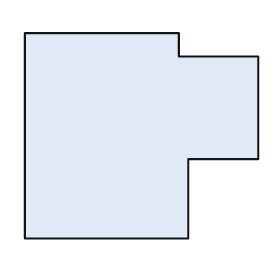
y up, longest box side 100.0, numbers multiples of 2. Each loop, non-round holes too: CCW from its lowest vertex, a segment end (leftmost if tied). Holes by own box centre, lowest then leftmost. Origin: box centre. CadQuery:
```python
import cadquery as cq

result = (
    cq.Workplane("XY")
    .moveTo(-50.0, -44.0)
    .lineTo(20.0, -44.0)
    .lineTo(20.0, -10.0)
    .lineTo(50.0, -10.0)
    .lineTo(50.0, 34.0)
    .lineTo(16.0, 34.0)
    .lineTo(16.0, 44.0)
    .lineTo(-50.0, 44.0)
    .close()
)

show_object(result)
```